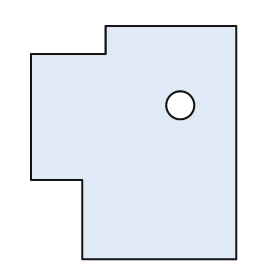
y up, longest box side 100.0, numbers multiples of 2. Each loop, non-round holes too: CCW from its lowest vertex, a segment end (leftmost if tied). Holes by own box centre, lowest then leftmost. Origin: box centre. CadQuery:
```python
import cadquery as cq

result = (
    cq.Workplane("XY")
    .moveTo(-22.0, -50.0)
    .lineTo(44.0, -50.0)
    .lineTo(44.0, 50.0)
    .lineTo(-12.0, 50.0)
    .lineTo(-12.0, 38.0)
    .lineTo(-44.0, 38.0)
    .lineTo(-44.0, -16.0)
    .lineTo(-22.0, -16.0)
    .close()
    .moveTo(20.0, 16.0)
    .circle(6.0)
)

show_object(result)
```